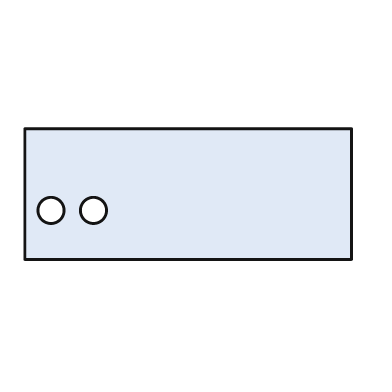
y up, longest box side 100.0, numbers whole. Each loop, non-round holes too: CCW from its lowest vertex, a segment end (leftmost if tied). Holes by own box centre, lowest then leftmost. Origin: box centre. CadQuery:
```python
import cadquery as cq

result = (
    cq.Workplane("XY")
    .moveTo(-50.0, -20.0)
    .lineTo(50.0, -20.0)
    .lineTo(50.0, 20.0)
    .lineTo(-50.0, 20.0)
    .close()
    .moveTo(-42.0, -5.0)
    .circle(4.0)
    .moveTo(-29.0, -5.0)
    .circle(4.0)
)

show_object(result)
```